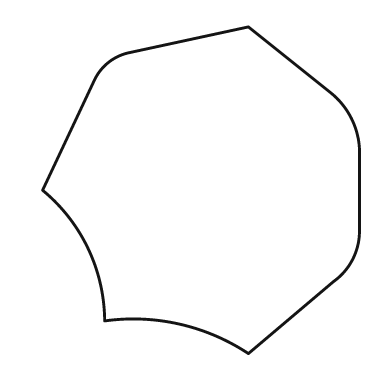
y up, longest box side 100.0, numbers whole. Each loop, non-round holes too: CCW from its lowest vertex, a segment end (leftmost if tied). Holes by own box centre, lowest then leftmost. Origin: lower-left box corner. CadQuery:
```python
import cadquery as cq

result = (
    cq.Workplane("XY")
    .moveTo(63.0, 0.0)
    .lineTo(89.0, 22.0)
    .threePointArc((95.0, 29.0), (97.0, 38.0))
    .lineTo(97.0, 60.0)
    .threePointArc((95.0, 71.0), (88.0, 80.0))
    .lineTo(63.0, 100.0)
    .lineTo(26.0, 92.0)
    .threePointArc((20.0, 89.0), (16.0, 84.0))
    .lineTo(0.0, 50.0)
    .threePointArc((14.0, 32.0), (19.0, 10.0))
    .threePointArc((42.0, 9.0), (63.0, 0.0))
    .close()
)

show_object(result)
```